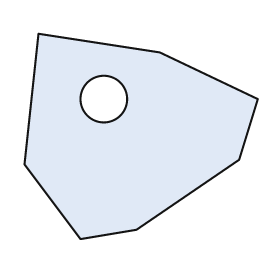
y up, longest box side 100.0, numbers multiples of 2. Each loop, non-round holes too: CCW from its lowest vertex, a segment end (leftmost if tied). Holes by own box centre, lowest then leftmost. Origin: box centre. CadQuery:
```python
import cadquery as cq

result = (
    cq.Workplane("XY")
    .moveTo(-26.0, -44.0)
    .lineTo(-2.0, -40.0)
    .lineTo(42.0, -10.0)
    .lineTo(50.0, 16.0)
    .lineTo(8.0, 36.0)
    .lineTo(-44.0, 44.0)
    .lineTo(-50.0, -12.0)
    .close()
    .moveTo(-16.0, 16.0)
    .circle(10.0)
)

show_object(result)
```